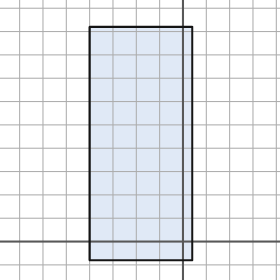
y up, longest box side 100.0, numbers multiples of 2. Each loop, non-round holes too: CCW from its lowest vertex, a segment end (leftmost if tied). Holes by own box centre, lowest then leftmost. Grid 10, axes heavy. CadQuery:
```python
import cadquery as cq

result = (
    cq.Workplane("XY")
    .moveTo(-40.0, -8.0)
    .lineTo(4.0, -8.0)
    .lineTo(4.0, 92.0)
    .lineTo(-40.0, 92.0)
    .close()
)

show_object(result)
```